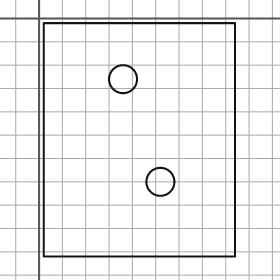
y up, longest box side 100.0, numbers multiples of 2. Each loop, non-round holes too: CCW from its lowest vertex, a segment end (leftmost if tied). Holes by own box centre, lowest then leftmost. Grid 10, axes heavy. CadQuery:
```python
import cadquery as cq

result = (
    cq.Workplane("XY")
    .moveTo(2.0, -102.0)
    .lineTo(84.0, -102.0)
    .lineTo(84.0, -2.0)
    .lineTo(2.0, -2.0)
    .close()
    .moveTo(52.0, -70.0)
    .circle(6.0)
    .moveTo(36.0, -26.0)
    .circle(6.0)
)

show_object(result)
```